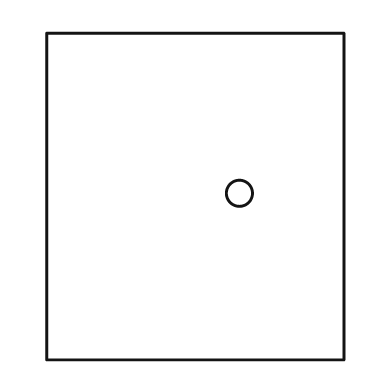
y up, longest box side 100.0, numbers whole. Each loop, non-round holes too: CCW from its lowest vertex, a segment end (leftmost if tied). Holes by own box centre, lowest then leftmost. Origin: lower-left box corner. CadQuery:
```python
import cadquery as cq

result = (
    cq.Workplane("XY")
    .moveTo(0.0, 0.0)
    .lineTo(91.0, 0.0)
    .lineTo(91.0, 100.0)
    .lineTo(0.0, 100.0)
    .close()
    .moveTo(59.0, 51.0)
    .circle(4.0)
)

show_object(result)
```